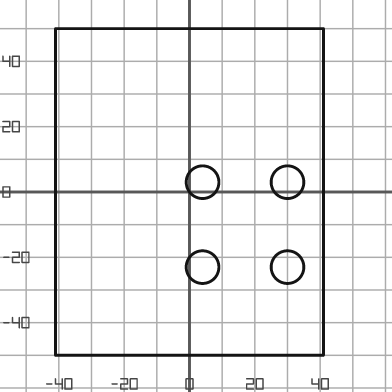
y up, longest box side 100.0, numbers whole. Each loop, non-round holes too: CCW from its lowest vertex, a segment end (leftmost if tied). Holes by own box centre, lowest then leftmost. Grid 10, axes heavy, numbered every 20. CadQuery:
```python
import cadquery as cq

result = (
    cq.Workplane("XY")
    .moveTo(-41.0, -50.0)
    .lineTo(41.0, -50.0)
    .lineTo(41.0, 50.0)
    .lineTo(-41.0, 50.0)
    .close()
    .moveTo(4.0, -23.0)
    .circle(5.0)
    .moveTo(30.0, -23.0)
    .circle(5.0)
    .moveTo(4.0, 3.0)
    .circle(5.0)
    .moveTo(30.0, 3.0)
    .circle(5.0)
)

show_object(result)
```